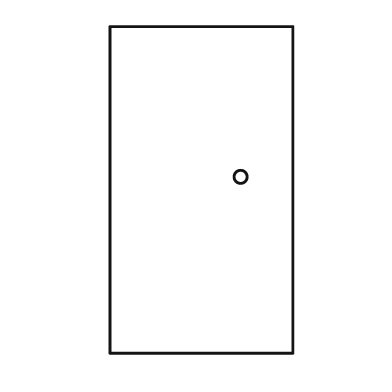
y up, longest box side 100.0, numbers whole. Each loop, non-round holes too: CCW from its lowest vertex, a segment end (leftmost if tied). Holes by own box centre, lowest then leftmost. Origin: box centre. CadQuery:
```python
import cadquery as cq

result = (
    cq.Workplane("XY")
    .moveTo(-28.0, -50.0)
    .lineTo(28.0, -50.0)
    .lineTo(28.0, 50.0)
    .lineTo(-28.0, 50.0)
    .close()
    .moveTo(12.0, 4.0)
    .circle(2.0)
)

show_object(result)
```